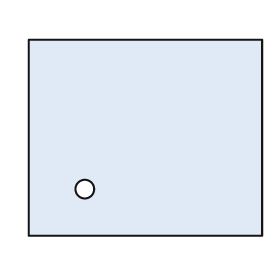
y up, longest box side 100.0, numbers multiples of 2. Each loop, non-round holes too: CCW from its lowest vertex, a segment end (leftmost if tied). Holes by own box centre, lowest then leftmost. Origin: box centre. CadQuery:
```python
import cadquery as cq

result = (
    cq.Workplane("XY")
    .moveTo(-50.0, -42.0)
    .lineTo(50.0, -42.0)
    .lineTo(50.0, 42.0)
    .lineTo(-50.0, 42.0)
    .close()
    .moveTo(-26.0, -22.0)
    .circle(4.0)
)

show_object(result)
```